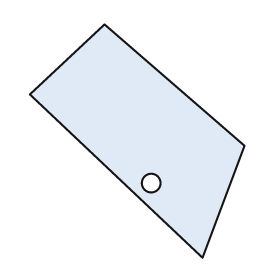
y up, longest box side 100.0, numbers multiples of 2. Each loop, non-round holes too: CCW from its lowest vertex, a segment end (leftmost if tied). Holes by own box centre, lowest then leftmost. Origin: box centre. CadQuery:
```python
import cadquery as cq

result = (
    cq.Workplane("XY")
    .moveTo(28.0, -50.0)
    .lineTo(46.0, -2.0)
    .lineTo(-14.0, 50.0)
    .lineTo(-46.0, 20.0)
    .close()
    .moveTo(6.0, -18.0)
    .circle(4.0)
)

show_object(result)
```